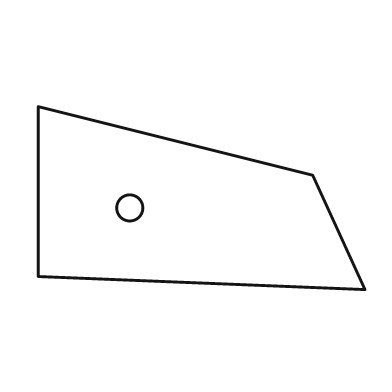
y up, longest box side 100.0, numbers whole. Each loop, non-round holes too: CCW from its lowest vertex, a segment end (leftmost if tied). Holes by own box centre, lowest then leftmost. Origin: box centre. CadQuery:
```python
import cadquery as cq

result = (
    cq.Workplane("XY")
    .moveTo(50.0, -28.0)
    .lineTo(34.0, 7.0)
    .lineTo(-50.0, 28.0)
    .lineTo(-50.0, -24.0)
    .close()
    .moveTo(-22.0, -3.0)
    .circle(4.0)
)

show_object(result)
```